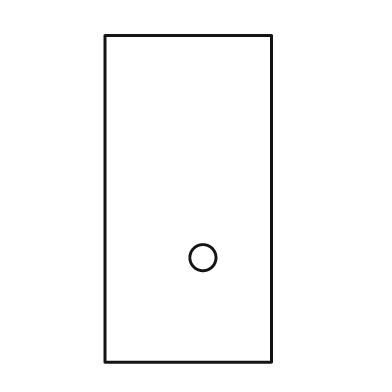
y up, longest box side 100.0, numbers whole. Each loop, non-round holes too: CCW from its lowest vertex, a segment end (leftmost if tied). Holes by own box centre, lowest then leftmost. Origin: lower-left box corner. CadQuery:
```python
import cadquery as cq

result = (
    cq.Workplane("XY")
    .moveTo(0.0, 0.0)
    .lineTo(51.0, 0.0)
    .lineTo(51.0, 100.0)
    .lineTo(0.0, 100.0)
    .close()
    .moveTo(30.0, 32.0)
    .circle(4.0)
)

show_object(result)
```